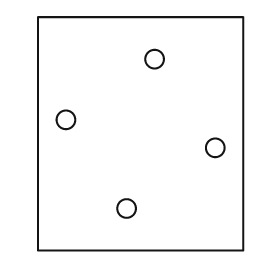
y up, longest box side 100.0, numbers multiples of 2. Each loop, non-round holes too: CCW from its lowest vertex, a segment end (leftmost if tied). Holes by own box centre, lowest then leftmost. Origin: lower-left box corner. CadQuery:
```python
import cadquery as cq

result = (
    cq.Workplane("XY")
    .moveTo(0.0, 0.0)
    .lineTo(88.0, 0.0)
    .lineTo(88.0, 100.0)
    .lineTo(0.0, 100.0)
    .close()
    .moveTo(38.0, 18.0)
    .circle(4.0)
    .moveTo(76.0, 44.0)
    .circle(4.0)
    .moveTo(12.0, 56.0)
    .circle(4.0)
    .moveTo(50.0, 82.0)
    .circle(4.0)
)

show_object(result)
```